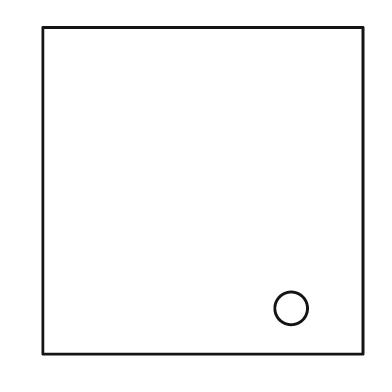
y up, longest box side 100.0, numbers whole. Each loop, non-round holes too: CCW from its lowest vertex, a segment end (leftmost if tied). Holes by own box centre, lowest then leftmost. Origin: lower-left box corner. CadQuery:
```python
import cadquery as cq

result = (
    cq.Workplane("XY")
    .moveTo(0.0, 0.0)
    .lineTo(98.0, 0.0)
    .lineTo(98.0, 100.0)
    .lineTo(0.0, 100.0)
    .close()
    .moveTo(76.0, 14.0)
    .circle(5.0)
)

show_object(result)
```